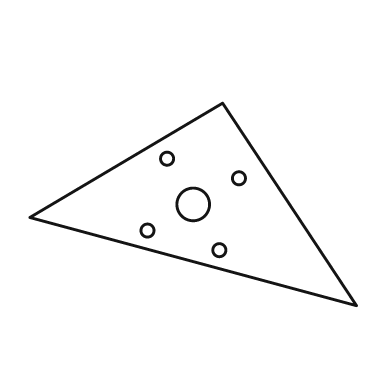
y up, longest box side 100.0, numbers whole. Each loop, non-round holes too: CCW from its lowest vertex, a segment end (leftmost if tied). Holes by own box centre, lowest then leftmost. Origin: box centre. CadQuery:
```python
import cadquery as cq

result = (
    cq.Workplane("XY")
    .moveTo(50.0, -31.0)
    .lineTo(9.0, 31.0)
    .lineTo(-50.0, -4.0)
    .close()
    .moveTo(8.0, -14.0)
    .circle(2.0)
    .moveTo(-14.0, -8.0)
    .circle(2.0)
    .moveTo(0.0, 0.0)
    .circle(5.0)
    .moveTo(14.0, 8.0)
    .circle(2.0)
    .moveTo(-8.0, 14.0)
    .circle(2.0)
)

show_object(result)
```